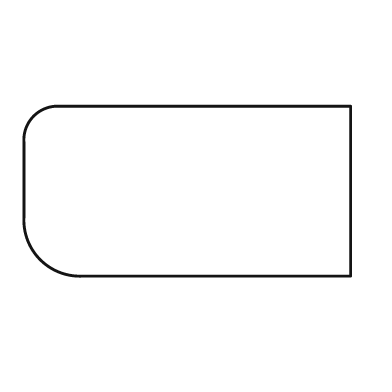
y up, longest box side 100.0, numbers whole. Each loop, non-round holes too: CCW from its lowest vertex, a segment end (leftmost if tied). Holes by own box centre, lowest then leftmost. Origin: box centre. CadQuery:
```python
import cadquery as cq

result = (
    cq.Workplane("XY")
    .moveTo(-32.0, -26.0)
    .lineTo(50.0, -26.0)
    .lineTo(50.0, 26.0)
    .lineTo(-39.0, 26.0)
    .threePointArc((-47.0, 23.0), (-50.0, 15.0))
    .lineTo(-50.0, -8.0)
    .threePointArc((-45.0, -21.0), (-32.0, -26.0))
    .close()
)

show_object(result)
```